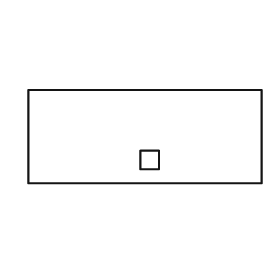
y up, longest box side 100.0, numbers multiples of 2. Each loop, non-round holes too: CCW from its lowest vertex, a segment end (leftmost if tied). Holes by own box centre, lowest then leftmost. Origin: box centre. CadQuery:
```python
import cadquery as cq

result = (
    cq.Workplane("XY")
    .moveTo(-50.0, -20.0)
    .lineTo(50.0, -20.0)
    .lineTo(50.0, 20.0)
    .lineTo(-50.0, 20.0)
    .close()
    .moveTo(-2.0, -14.0)
    .lineTo(6.0, -14.0)
    .lineTo(6.0, -6.0)
    .lineTo(-2.0, -6.0)
    .close()
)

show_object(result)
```